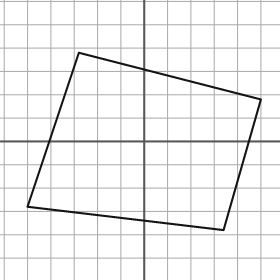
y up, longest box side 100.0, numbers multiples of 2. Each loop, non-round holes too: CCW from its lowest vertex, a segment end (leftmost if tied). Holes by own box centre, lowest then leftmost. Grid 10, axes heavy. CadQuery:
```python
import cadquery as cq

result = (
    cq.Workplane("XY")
    .moveTo(34.0, -38.0)
    .lineTo(50.0, 18.0)
    .lineTo(-28.0, 38.0)
    .lineTo(-50.0, -28.0)
    .close()
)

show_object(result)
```